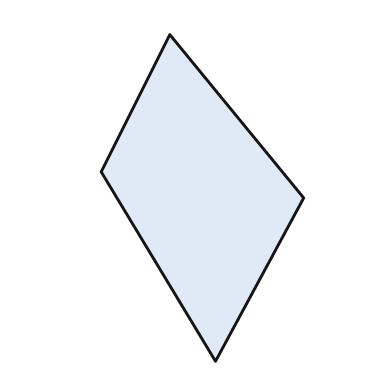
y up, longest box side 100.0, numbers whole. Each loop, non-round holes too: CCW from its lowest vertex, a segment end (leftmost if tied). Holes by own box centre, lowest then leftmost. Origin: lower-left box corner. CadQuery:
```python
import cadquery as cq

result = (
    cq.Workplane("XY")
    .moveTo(35.0, 0.0)
    .lineTo(62.0, 50.0)
    .lineTo(21.0, 100.0)
    .lineTo(0.0, 58.0)
    .close()
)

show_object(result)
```